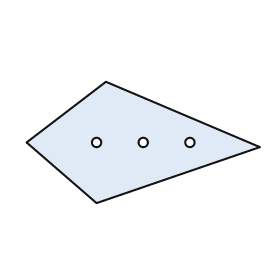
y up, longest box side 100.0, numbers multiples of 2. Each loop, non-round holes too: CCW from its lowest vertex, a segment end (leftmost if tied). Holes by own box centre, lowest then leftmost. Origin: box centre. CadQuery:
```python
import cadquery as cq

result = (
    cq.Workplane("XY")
    .moveTo(-20.0, -26.0)
    .lineTo(50.0, -2.0)
    .lineTo(-16.0, 26.0)
    .lineTo(-50.0, 0.0)
    .close()
    .moveTo(-20.0, 0.0)
    .circle(2.0)
    .moveTo(0.0, 0.0)
    .circle(2.0)
    .moveTo(20.0, 0.0)
    .circle(2.0)
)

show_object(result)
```